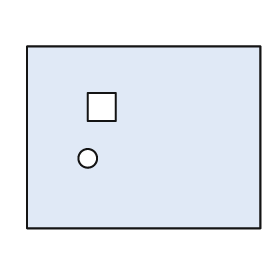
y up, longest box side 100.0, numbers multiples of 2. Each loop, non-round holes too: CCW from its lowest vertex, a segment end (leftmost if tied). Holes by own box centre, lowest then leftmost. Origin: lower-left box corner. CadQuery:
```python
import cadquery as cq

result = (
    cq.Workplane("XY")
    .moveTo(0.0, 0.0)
    .lineTo(100.0, 0.0)
    .lineTo(100.0, 78.0)
    .lineTo(0.0, 78.0)
    .close()
    .moveTo(26.0, 30.0)
    .circle(4.0)
    .moveTo(26.0, 46.0)
    .lineTo(38.0, 46.0)
    .lineTo(38.0, 58.0)
    .lineTo(26.0, 58.0)
    .close()
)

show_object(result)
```